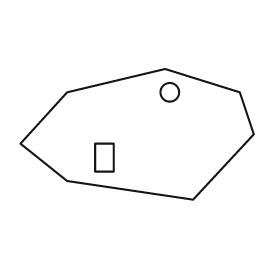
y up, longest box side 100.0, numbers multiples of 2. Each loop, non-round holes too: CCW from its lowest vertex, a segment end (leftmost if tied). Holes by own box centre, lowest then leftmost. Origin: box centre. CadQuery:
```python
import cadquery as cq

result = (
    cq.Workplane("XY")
    .moveTo(24.0, -28.0)
    .lineTo(50.0, 0.0)
    .lineTo(44.0, 18.0)
    .lineTo(12.0, 28.0)
    .lineTo(-30.0, 18.0)
    .lineTo(-50.0, -4.0)
    .lineTo(-30.0, -20.0)
    .close()
    .moveTo(-18.0, -16.0)
    .lineTo(-10.0, -16.0)
    .lineTo(-10.0, -4.0)
    .lineTo(-18.0, -4.0)
    .close()
    .moveTo(14.0, 18.0)
    .circle(4.0)
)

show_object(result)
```